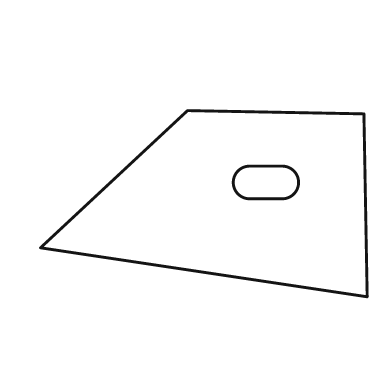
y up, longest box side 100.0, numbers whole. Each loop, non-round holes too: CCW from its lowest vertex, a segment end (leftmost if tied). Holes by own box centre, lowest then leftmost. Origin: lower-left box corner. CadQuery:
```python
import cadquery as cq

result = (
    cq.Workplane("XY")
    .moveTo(100.0, 0.0)
    .lineTo(99.0, 56.0)
    .lineTo(45.0, 57.0)
    .lineTo(0.0, 15.0)
    .close()
    .moveTo(64.0, 30.0)
    .lineTo(74.0, 30.0)
    .threePointArc((79.0, 35.0), (74.0, 40.0))
    .lineTo(64.0, 40.0)
    .threePointArc((59.0, 35.0), (64.0, 30.0))
    .close()
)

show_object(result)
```